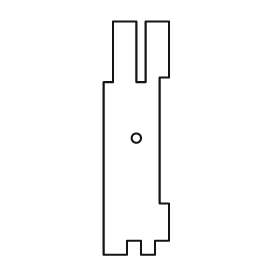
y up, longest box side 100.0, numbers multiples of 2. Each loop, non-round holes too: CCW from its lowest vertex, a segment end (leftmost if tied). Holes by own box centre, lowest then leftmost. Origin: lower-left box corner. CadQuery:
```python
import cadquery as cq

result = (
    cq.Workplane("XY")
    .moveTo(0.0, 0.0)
    .lineTo(10.0, 0.0)
    .lineTo(10.0, 6.0)
    .lineTo(16.0, 6.0)
    .lineTo(16.0, 0.0)
    .lineTo(22.0, 0.0)
    .lineTo(22.0, 6.0)
    .lineTo(28.0, 6.0)
    .lineTo(28.0, 22.0)
    .lineTo(24.0, 22.0)
    .lineTo(24.0, 76.0)
    .lineTo(28.0, 76.0)
    .lineTo(28.0, 100.0)
    .lineTo(18.0, 100.0)
    .lineTo(18.0, 74.0)
    .lineTo(14.0, 74.0)
    .lineTo(14.0, 100.0)
    .lineTo(4.0, 100.0)
    .lineTo(4.0, 74.0)
    .lineTo(0.0, 74.0)
    .close()
    .moveTo(14.0, 50.0)
    .circle(2.0)
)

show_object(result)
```